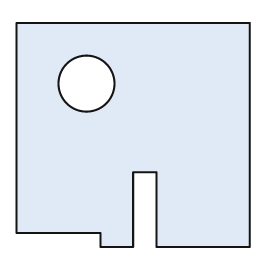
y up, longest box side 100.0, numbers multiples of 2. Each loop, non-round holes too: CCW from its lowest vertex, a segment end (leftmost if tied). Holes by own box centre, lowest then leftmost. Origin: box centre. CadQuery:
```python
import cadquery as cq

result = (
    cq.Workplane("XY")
    .moveTo(-14.0, -48.0)
    .lineTo(0.0, -48.0)
    .lineTo(0.0, -16.0)
    .lineTo(10.0, -16.0)
    .lineTo(10.0, -48.0)
    .lineTo(50.0, -48.0)
    .lineTo(50.0, 48.0)
    .lineTo(-50.0, 48.0)
    .lineTo(-50.0, -42.0)
    .lineTo(-14.0, -42.0)
    .close()
    .moveTo(-20.0, 22.0)
    .circle(12.0)
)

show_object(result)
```